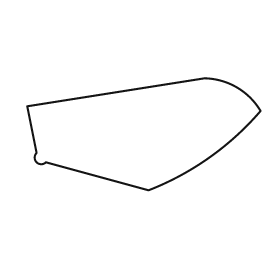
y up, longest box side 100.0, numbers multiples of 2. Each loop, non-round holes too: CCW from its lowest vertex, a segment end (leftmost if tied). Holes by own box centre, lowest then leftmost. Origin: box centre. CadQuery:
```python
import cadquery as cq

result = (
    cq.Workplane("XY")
    .moveTo(2.0, -24.0)
    .threePointArc((28.0, -10.0), (50.0, 10.0))
    .threePointArc((40.0, 20.0), (26.0, 24.0))
    .lineTo(-50.0, 12.0)
    .lineTo(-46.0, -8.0)
    .threePointArc((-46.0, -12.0), (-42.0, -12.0))
    .close()
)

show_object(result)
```